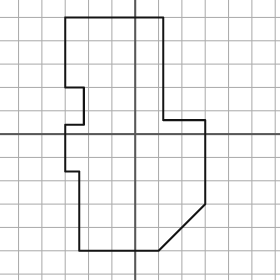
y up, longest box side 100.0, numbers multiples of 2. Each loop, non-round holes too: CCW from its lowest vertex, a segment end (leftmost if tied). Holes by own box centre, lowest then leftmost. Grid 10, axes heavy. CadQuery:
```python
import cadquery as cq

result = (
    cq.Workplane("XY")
    .moveTo(-24.0, -50.0)
    .lineTo(10.0, -50.0)
    .lineTo(30.0, -30.0)
    .lineTo(30.0, 6.0)
    .lineTo(12.0, 6.0)
    .lineTo(12.0, 50.0)
    .lineTo(-30.0, 50.0)
    .lineTo(-30.0, 20.0)
    .lineTo(-22.0, 20.0)
    .lineTo(-22.0, 4.0)
    .lineTo(-30.0, 4.0)
    .lineTo(-30.0, -16.0)
    .lineTo(-24.0, -16.0)
    .close()
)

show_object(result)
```